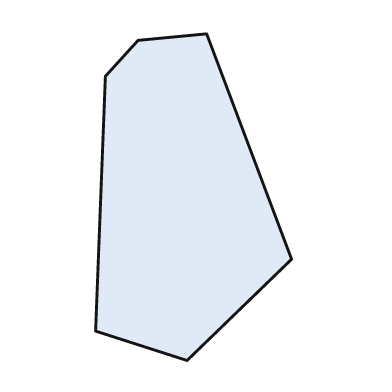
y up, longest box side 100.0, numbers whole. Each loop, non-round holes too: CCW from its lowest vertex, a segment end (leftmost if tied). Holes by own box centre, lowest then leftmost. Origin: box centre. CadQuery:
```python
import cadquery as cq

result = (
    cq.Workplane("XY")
    .moveTo(-2.0, -50.0)
    .lineTo(30.0, -19.0)
    .lineTo(4.0, 50.0)
    .lineTo(-17.0, 48.0)
    .lineTo(-27.0, 37.0)
    .lineTo(-30.0, -41.0)
    .close()
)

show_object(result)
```